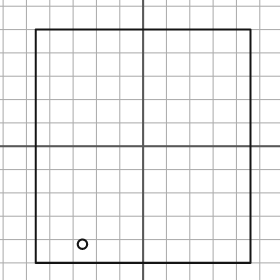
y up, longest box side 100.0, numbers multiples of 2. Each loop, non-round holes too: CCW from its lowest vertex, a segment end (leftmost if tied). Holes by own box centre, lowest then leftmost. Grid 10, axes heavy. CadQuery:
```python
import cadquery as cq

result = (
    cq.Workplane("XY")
    .moveTo(-46.0, -50.0)
    .lineTo(46.0, -50.0)
    .lineTo(46.0, 50.0)
    .lineTo(-46.0, 50.0)
    .close()
    .moveTo(-26.0, -42.0)
    .circle(2.0)
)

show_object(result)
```